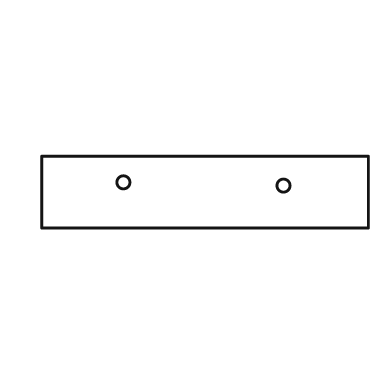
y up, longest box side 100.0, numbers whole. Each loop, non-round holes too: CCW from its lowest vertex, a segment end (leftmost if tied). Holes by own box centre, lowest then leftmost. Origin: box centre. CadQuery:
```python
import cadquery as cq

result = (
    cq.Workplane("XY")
    .moveTo(-50.0, -11.0)
    .lineTo(50.0, -11.0)
    .lineTo(50.0, 11.0)
    .lineTo(-50.0, 11.0)
    .close()
    .moveTo(24.0, 2.0)
    .circle(2.0)
    .moveTo(-25.0, 3.0)
    .circle(2.0)
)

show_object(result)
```